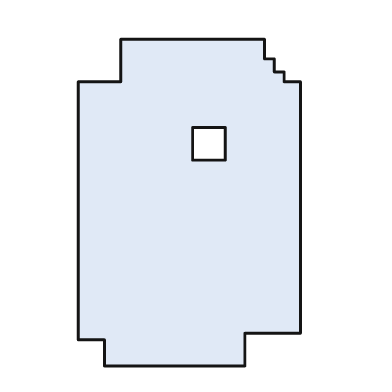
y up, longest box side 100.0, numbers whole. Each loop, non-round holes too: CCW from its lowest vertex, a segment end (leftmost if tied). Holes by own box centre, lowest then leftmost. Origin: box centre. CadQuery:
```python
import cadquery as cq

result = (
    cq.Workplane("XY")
    .moveTo(-26.0, -50.0)
    .lineTo(17.0, -50.0)
    .lineTo(17.0, -40.0)
    .lineTo(34.0, -40.0)
    .lineTo(34.0, 37.0)
    .lineTo(29.0, 37.0)
    .lineTo(29.0, 40.0)
    .lineTo(26.0, 40.0)
    .lineTo(26.0, 44.0)
    .lineTo(23.0, 44.0)
    .lineTo(23.0, 50.0)
    .lineTo(-21.0, 50.0)
    .lineTo(-21.0, 37.0)
    .lineTo(-34.0, 37.0)
    .lineTo(-34.0, -42.0)
    .lineTo(-26.0, -42.0)
    .close()
    .moveTo(1.0, 13.0)
    .lineTo(11.0, 13.0)
    .lineTo(11.0, 23.0)
    .lineTo(1.0, 23.0)
    .close()
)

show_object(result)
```